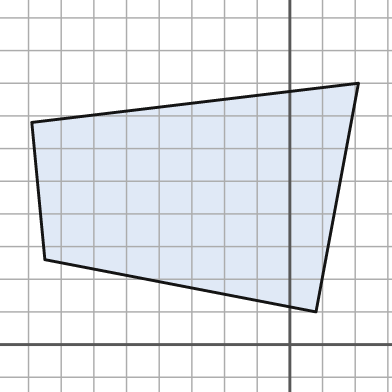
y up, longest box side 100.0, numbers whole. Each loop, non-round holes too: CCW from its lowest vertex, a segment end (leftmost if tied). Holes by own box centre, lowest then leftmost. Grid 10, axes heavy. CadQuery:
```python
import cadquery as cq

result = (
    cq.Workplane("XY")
    .moveTo(8.0, 10.0)
    .lineTo(21.0, 80.0)
    .lineTo(-79.0, 68.0)
    .lineTo(-75.0, 26.0)
    .close()
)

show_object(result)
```